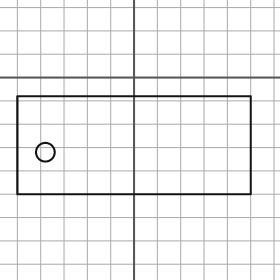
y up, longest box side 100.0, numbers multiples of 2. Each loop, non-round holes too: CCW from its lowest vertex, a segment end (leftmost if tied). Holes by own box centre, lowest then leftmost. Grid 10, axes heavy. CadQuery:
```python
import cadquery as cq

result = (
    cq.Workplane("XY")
    .moveTo(-50.0, -50.0)
    .lineTo(50.0, -50.0)
    .lineTo(50.0, -8.0)
    .lineTo(-50.0, -8.0)
    .close()
    .moveTo(-38.0, -32.0)
    .circle(4.0)
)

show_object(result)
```